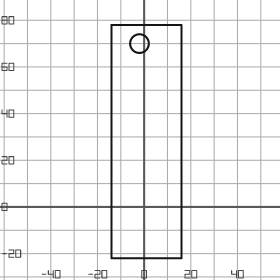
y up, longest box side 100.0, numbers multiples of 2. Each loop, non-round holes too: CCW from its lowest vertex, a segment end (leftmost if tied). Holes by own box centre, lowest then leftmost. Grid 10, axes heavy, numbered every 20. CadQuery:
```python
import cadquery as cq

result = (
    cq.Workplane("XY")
    .moveTo(-14.0, -22.0)
    .lineTo(16.0, -22.0)
    .lineTo(16.0, 78.0)
    .lineTo(-14.0, 78.0)
    .close()
    .moveTo(-2.0, 70.0)
    .circle(4.0)
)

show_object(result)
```